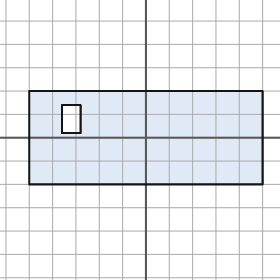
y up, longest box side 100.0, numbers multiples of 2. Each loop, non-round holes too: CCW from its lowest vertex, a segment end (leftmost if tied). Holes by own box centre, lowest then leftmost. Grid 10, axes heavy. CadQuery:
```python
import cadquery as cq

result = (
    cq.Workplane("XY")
    .moveTo(-50.0, -20.0)
    .lineTo(50.0, -20.0)
    .lineTo(50.0, 20.0)
    .lineTo(-50.0, 20.0)
    .close()
    .moveTo(-36.0, 2.0)
    .lineTo(-28.0, 2.0)
    .lineTo(-28.0, 14.0)
    .lineTo(-36.0, 14.0)
    .close()
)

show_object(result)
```